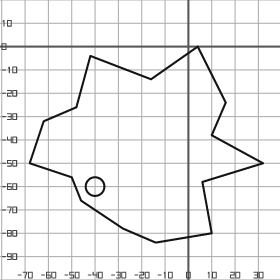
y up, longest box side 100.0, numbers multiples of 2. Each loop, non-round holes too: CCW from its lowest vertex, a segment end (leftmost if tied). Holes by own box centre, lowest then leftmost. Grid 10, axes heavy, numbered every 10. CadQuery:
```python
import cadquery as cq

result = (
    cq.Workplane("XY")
    .moveTo(-14.0, -84.0)
    .lineTo(10.0, -80.0)
    .lineTo(6.0, -58.0)
    .lineTo(32.0, -50.0)
    .lineTo(10.0, -38.0)
    .lineTo(16.0, -24.0)
    .lineTo(4.0, 0.0)
    .lineTo(-16.0, -14.0)
    .lineTo(-42.0, -4.0)
    .lineTo(-48.0, -26.0)
    .lineTo(-62.0, -32.0)
    .lineTo(-68.0, -50.0)
    .lineTo(-50.0, -56.0)
    .lineTo(-46.0, -66.0)
    .lineTo(-28.0, -78.0)
    .close()
    .moveTo(-40.0, -60.0)
    .circle(4.0)
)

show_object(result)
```